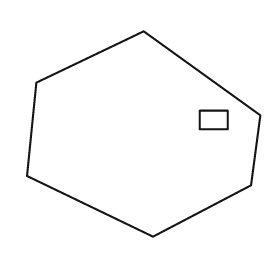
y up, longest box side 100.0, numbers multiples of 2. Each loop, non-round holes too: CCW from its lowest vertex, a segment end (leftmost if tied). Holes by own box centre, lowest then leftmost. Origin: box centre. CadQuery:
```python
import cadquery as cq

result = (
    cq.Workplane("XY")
    .moveTo(4.0, -44.0)
    .lineTo(46.0, -22.0)
    .lineTo(50.0, 8.0)
    .lineTo(0.0, 44.0)
    .lineTo(-46.0, 22.0)
    .lineTo(-50.0, -18.0)
    .close()
    .moveTo(24.0, 2.0)
    .lineTo(36.0, 2.0)
    .lineTo(36.0, 10.0)
    .lineTo(24.0, 10.0)
    .close()
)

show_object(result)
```